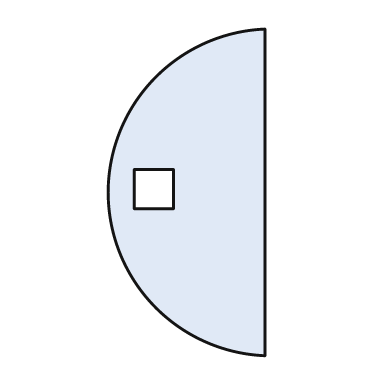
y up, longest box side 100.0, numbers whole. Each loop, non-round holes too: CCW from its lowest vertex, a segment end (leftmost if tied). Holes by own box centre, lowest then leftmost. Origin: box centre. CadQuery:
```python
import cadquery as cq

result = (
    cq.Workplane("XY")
    .moveTo(24.0, -50.0)
    .lineTo(24.0, 50.0)
    .threePointArc((-24.0, 0.0), (24.0, -50.0))
    .close()
    .moveTo(-16.0, -5.0)
    .lineTo(-4.0, -5.0)
    .lineTo(-4.0, 7.0)
    .lineTo(-16.0, 7.0)
    .close()
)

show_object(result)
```